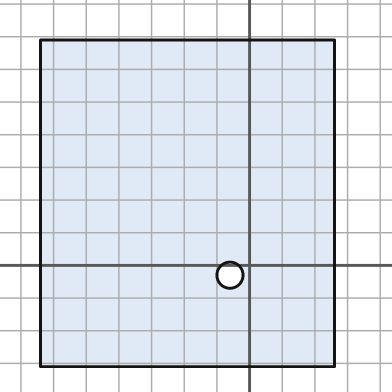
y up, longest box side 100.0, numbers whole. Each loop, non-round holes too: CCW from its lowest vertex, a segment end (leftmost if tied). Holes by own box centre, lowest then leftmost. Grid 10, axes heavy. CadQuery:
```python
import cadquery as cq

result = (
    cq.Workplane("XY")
    .moveTo(-64.0, -31.0)
    .lineTo(26.0, -31.0)
    .lineTo(26.0, 69.0)
    .lineTo(-64.0, 69.0)
    .close()
    .moveTo(-6.0, -3.0)
    .circle(4.0)
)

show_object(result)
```